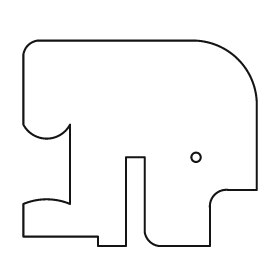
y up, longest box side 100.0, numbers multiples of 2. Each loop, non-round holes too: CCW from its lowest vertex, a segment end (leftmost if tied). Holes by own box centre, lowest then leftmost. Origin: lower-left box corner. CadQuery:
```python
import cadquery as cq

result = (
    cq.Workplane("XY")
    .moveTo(32.0, 0.0)
    .lineTo(44.0, 0.0)
    .lineTo(44.0, 38.0)
    .lineTo(52.0, 38.0)
    .lineTo(52.0, 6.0)
    .threePointArc((54.0, 2.0), (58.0, 0.0))
    .lineTo(80.0, 0.0)
    .lineTo(80.0, 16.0)
    .threePointArc((82.0, 22.0), (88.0, 24.0))
    .lineTo(100.0, 24.0)
    .lineTo(100.0, 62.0)
    .threePointArc((92.0, 80.0), (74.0, 88.0))
    .lineTo(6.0, 88.0)
    .threePointArc((2.0, 86.0), (0.0, 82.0))
    .lineTo(0.0, 52.0)
    .threePointArc((10.0, 46.0), (20.0, 52.0))
    .lineTo(20.0, 18.0)
    .threePointArc((10.0, 20.0), (0.0, 18.0))
    .lineTo(0.0, 4.0)
    .lineTo(32.0, 4.0)
    .close()
    .moveTo(74.0, 38.0)
    .circle(2.0)
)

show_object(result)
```